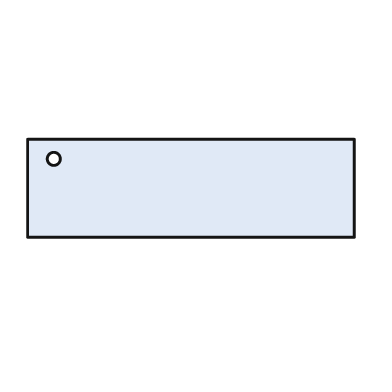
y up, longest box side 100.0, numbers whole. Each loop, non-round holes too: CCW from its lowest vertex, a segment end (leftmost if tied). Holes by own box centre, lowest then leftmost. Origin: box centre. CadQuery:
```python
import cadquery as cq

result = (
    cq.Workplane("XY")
    .moveTo(-50.0, -15.0)
    .lineTo(50.0, -15.0)
    .lineTo(50.0, 15.0)
    .lineTo(-50.0, 15.0)
    .close()
    .moveTo(-42.0, 9.0)
    .circle(2.0)
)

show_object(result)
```